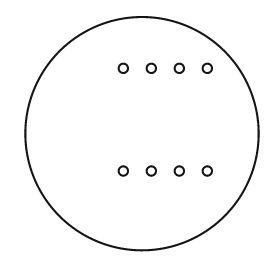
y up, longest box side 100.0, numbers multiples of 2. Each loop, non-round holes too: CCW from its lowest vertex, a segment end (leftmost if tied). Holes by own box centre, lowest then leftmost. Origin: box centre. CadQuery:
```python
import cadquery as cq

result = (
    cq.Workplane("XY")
    .moveTo(0.0, 0.0)
    .circle(50.0)
    .moveTo(-8.0, -16.0)
    .circle(2.0)
    .moveTo(4.0, -16.0)
    .circle(2.0)
    .moveTo(16.0, -16.0)
    .circle(2.0)
    .moveTo(28.0, -16.0)
    .circle(2.0)
    .moveTo(-8.0, 28.0)
    .circle(2.0)
    .moveTo(4.0, 28.0)
    .circle(2.0)
    .moveTo(16.0, 28.0)
    .circle(2.0)
    .moveTo(28.0, 28.0)
    .circle(2.0)
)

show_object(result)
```